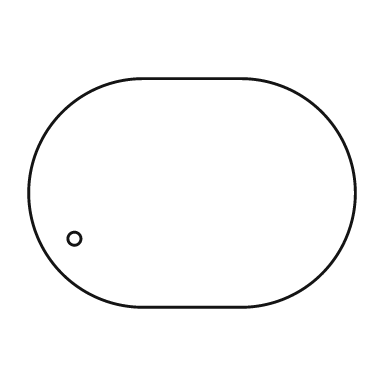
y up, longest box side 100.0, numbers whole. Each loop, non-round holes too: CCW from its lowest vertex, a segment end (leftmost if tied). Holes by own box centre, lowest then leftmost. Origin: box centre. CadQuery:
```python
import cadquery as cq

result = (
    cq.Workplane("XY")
    .moveTo(-15.0, -35.0)
    .lineTo(15.0, -35.0)
    .threePointArc((50.0, 0.0), (15.0, 35.0))
    .lineTo(-15.0, 35.0)
    .threePointArc((-50.0, 0.0), (-15.0, -35.0))
    .close()
    .moveTo(-36.0, -14.0)
    .circle(2.0)
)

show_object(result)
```